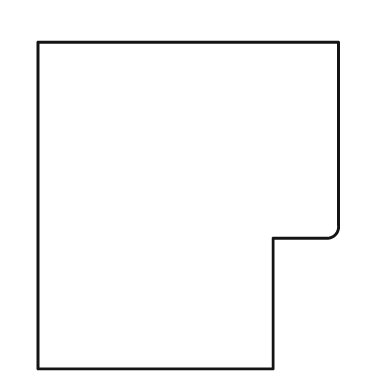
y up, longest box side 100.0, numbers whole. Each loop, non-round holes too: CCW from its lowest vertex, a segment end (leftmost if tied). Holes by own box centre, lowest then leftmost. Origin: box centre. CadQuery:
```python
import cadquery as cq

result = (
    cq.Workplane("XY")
    .moveTo(-46.0, -50.0)
    .lineTo(26.0, -50.0)
    .lineTo(26.0, -10.0)
    .lineTo(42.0, -10.0)
    .threePointArc((45.0, -9.0), (46.0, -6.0))
    .lineTo(46.0, 50.0)
    .lineTo(-46.0, 50.0)
    .close()
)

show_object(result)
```